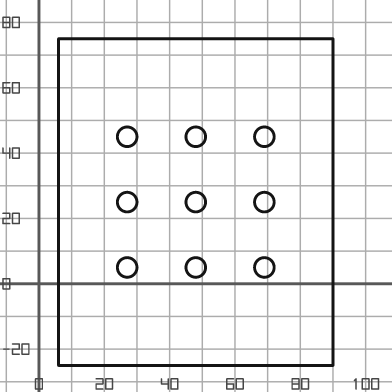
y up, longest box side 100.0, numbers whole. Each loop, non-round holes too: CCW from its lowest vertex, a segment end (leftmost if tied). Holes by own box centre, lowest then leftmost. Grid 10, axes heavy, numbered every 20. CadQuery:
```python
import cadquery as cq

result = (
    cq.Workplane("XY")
    .moveTo(6.0, -25.0)
    .lineTo(90.0, -25.0)
    .lineTo(90.0, 75.0)
    .lineTo(6.0, 75.0)
    .close()
    .moveTo(27.0, 5.0)
    .circle(3.0)
    .moveTo(48.0, 5.0)
    .circle(3.0)
    .moveTo(69.0, 5.0)
    .circle(3.0)
    .moveTo(27.0, 25.0)
    .circle(3.0)
    .moveTo(48.0, 25.0)
    .circle(3.0)
    .moveTo(69.0, 25.0)
    .circle(3.0)
    .moveTo(27.0, 45.0)
    .circle(3.0)
    .moveTo(48.0, 45.0)
    .circle(3.0)
    .moveTo(69.0, 45.0)
    .circle(3.0)
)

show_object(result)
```